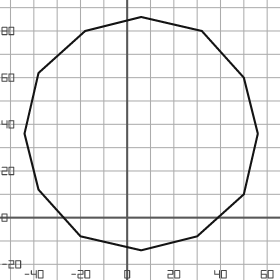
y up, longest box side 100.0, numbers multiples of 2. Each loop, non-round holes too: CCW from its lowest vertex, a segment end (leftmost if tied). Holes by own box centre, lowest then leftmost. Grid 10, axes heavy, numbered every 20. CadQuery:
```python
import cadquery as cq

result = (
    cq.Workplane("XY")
    .moveTo(6.0, -14.0)
    .lineTo(30.0, -8.0)
    .lineTo(50.0, 10.0)
    .lineTo(56.0, 36.0)
    .lineTo(50.0, 60.0)
    .lineTo(32.0, 80.0)
    .lineTo(6.0, 86.0)
    .lineTo(-18.0, 80.0)
    .lineTo(-38.0, 62.0)
    .lineTo(-44.0, 36.0)
    .lineTo(-38.0, 12.0)
    .lineTo(-20.0, -8.0)
    .close()
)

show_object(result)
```